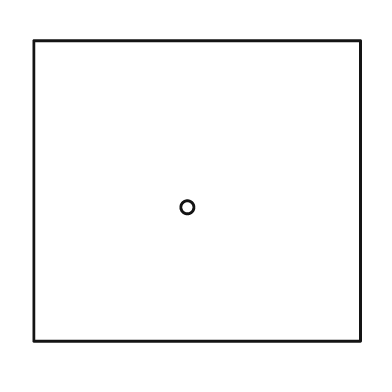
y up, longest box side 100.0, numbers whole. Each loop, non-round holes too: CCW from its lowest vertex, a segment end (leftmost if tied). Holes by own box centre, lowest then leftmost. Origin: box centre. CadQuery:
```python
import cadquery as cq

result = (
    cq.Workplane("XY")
    .moveTo(-50.0, -46.0)
    .lineTo(50.0, -46.0)
    .lineTo(50.0, 46.0)
    .lineTo(-50.0, 46.0)
    .close()
    .moveTo(-3.0, -5.0)
    .circle(2.0)
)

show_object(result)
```